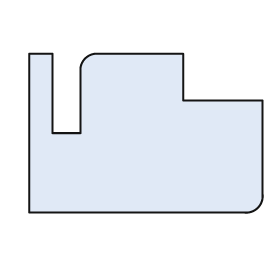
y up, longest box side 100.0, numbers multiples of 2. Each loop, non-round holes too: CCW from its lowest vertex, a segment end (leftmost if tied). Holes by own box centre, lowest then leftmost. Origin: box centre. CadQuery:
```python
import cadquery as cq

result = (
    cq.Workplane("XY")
    .moveTo(-50.0, -34.0)
    .lineTo(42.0, -34.0)
    .threePointArc((48.0, -32.0), (50.0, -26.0))
    .lineTo(50.0, 14.0)
    .lineTo(16.0, 14.0)
    .lineTo(16.0, 34.0)
    .lineTo(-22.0, 34.0)
    .threePointArc((-26.0, 32.0), (-28.0, 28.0))
    .lineTo(-28.0, 0.0)
    .lineTo(-40.0, 0.0)
    .lineTo(-40.0, 34.0)
    .lineTo(-50.0, 34.0)
    .close()
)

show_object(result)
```